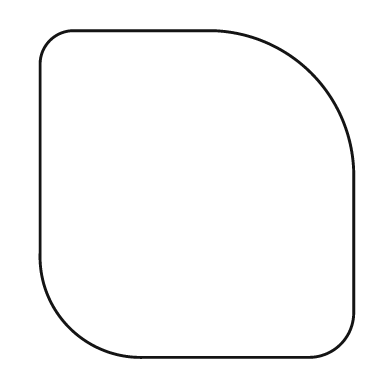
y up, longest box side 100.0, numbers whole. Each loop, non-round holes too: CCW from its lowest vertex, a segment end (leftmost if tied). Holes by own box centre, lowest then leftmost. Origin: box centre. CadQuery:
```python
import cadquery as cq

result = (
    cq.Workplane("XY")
    .moveTo(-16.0, -50.0)
    .lineTo(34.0, -50.0)
    .threePointArc((44.0, -46.0), (48.0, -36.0))
    .lineTo(48.0, 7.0)
    .threePointArc((35.0, 37.0), (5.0, 50.0))
    .lineTo(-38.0, 50.0)
    .threePointArc((-45.0, 47.0), (-48.0, 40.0))
    .lineTo(-48.0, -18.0)
    .threePointArc((-39.0, -41.0), (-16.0, -50.0))
    .close()
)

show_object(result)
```